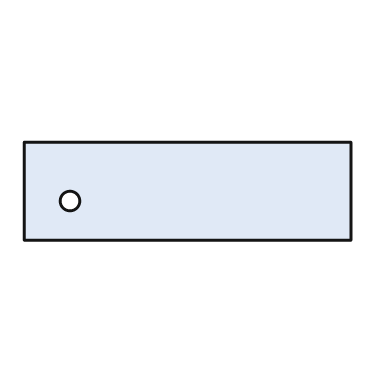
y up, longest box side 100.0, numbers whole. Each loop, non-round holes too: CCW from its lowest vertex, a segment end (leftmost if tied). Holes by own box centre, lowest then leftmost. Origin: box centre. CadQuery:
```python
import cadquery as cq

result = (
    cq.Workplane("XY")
    .moveTo(-50.0, -15.0)
    .lineTo(50.0, -15.0)
    .lineTo(50.0, 15.0)
    .lineTo(-50.0, 15.0)
    .close()
    .moveTo(-36.0, -3.0)
    .circle(3.0)
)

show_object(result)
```